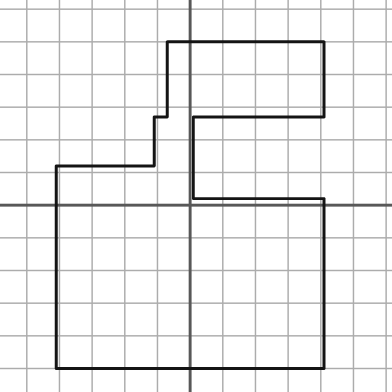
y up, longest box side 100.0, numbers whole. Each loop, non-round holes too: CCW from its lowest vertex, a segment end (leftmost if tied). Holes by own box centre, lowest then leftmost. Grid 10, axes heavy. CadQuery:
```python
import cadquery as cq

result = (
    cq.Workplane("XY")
    .moveTo(-41.0, -50.0)
    .lineTo(41.0, -50.0)
    .lineTo(41.0, 2.0)
    .lineTo(1.0, 2.0)
    .lineTo(1.0, 27.0)
    .lineTo(41.0, 27.0)
    .lineTo(41.0, 50.0)
    .lineTo(-7.0, 50.0)
    .lineTo(-7.0, 27.0)
    .lineTo(-11.0, 27.0)
    .lineTo(-11.0, 12.0)
    .lineTo(-41.0, 12.0)
    .close()
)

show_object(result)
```